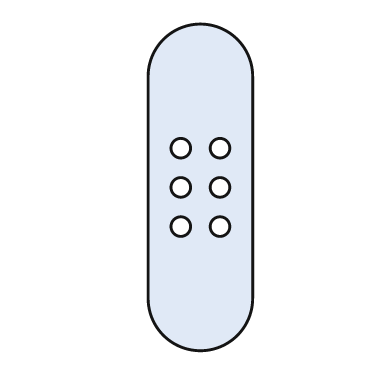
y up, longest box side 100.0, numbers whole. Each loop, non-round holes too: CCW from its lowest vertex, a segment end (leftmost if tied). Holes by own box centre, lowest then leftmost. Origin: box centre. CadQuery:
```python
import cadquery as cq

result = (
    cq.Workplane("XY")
    .moveTo(-16.0, -34.0)
    .threePointArc((0.0, -50.0), (16.0, -34.0))
    .lineTo(16.0, 34.0)
    .threePointArc((0.0, 50.0), (-16.0, 34.0))
    .close()
    .moveTo(-6.0, -12.0)
    .circle(3.0)
    .moveTo(6.0, -12.0)
    .circle(3.0)
    .moveTo(-6.0, 0.0)
    .circle(3.0)
    .moveTo(6.0, 0.0)
    .circle(3.0)
    .moveTo(-6.0, 12.0)
    .circle(3.0)
    .moveTo(6.0, 12.0)
    .circle(3.0)
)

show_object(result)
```